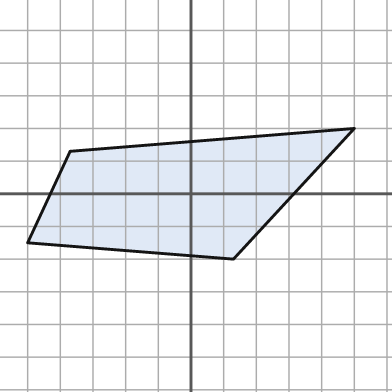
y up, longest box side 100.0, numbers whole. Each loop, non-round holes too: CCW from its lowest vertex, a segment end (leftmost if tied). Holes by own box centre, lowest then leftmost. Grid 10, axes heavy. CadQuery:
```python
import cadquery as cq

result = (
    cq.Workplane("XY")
    .moveTo(13.0, -20.0)
    .lineTo(50.0, 20.0)
    .lineTo(-37.0, 13.0)
    .lineTo(-50.0, -15.0)
    .close()
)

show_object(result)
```